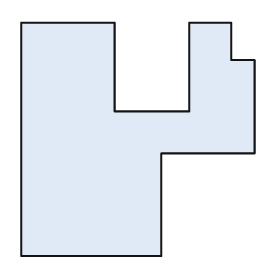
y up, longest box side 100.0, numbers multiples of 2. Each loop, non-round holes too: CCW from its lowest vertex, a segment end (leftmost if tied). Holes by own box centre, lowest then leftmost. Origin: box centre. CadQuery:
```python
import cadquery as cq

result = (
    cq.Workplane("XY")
    .moveTo(-50.0, -50.0)
    .lineTo(10.0, -50.0)
    .lineTo(10.0, -6.0)
    .lineTo(50.0, -6.0)
    .lineTo(50.0, 34.0)
    .lineTo(40.0, 34.0)
    .lineTo(40.0, 50.0)
    .lineTo(22.0, 50.0)
    .lineTo(22.0, 12.0)
    .lineTo(-10.0, 12.0)
    .lineTo(-10.0, 50.0)
    .lineTo(-50.0, 50.0)
    .close()
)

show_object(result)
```